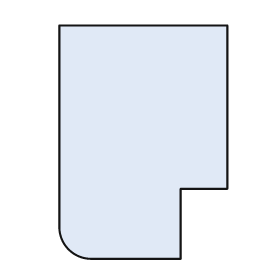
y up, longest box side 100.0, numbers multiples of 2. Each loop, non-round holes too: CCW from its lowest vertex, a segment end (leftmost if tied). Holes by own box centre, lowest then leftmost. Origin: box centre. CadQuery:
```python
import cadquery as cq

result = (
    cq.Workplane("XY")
    .moveTo(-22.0, -50.0)
    .lineTo(16.0, -50.0)
    .lineTo(16.0, -20.0)
    .lineTo(36.0, -20.0)
    .lineTo(36.0, 50.0)
    .lineTo(-36.0, 50.0)
    .lineTo(-36.0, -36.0)
    .threePointArc((-32.0, -46.0), (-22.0, -50.0))
    .close()
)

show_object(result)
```